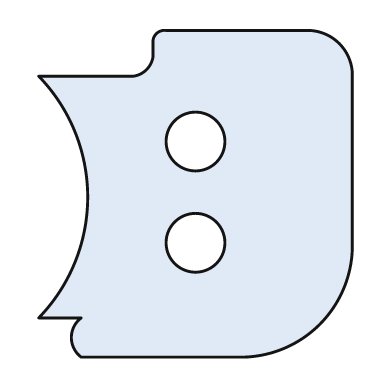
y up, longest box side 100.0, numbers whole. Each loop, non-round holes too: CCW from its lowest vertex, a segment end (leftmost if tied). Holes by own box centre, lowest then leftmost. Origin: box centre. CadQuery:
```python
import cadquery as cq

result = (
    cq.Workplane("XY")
    .moveTo(-35.0, -50.0)
    .lineTo(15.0, -50.0)
    .threePointArc((38.0, -40.0), (48.0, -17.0))
    .lineTo(48.0, 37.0)
    .threePointArc((44.0, 46.0), (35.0, 50.0))
    .lineTo(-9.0, 50.0)
    .threePointArc((-12.0, 49.0), (-13.0, 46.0))
    .lineTo(-13.0, 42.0)
    .threePointArc((-15.0, 38.0), (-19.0, 36.0))
    .lineTo(-48.0, 36.0)
    .threePointArc((-33.0, -1.0), (-48.0, -38.0))
    .lineTo(-35.0, -38.0)
    .threePointArc((-38.0, -44.0), (-35.0, -50.0))
    .close()
    .moveTo(0.0, -15.0)
    .circle(9.0)
    .moveTo(0.0, 16.0)
    .circle(9.0)
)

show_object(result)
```